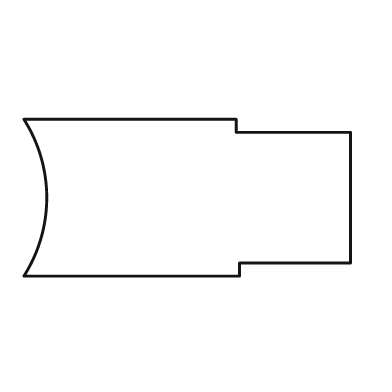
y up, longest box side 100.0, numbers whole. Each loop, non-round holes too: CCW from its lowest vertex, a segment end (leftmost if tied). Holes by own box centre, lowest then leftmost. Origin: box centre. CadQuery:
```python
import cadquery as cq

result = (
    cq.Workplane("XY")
    .moveTo(-50.0, -24.0)
    .lineTo(16.0, -24.0)
    .lineTo(16.0, -20.0)
    .lineTo(50.0, -20.0)
    .lineTo(50.0, 20.0)
    .lineTo(15.0, 20.0)
    .lineTo(15.0, 24.0)
    .lineTo(-50.0, 24.0)
    .threePointArc((-43.0, 0.0), (-50.0, -24.0))
    .close()
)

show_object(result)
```